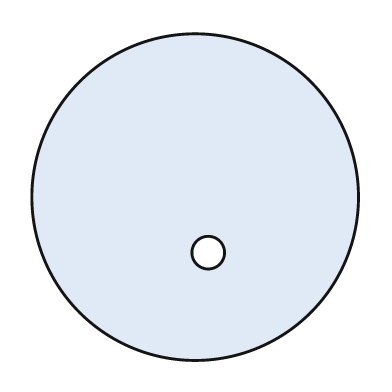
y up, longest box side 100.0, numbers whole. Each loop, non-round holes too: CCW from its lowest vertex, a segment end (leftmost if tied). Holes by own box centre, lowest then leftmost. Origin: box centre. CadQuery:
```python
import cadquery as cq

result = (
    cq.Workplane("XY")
    .moveTo(0.0, 0.0)
    .circle(50.0)
    .moveTo(4.0, -17.0)
    .circle(5.0)
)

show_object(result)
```